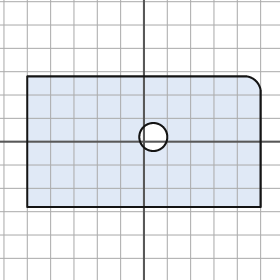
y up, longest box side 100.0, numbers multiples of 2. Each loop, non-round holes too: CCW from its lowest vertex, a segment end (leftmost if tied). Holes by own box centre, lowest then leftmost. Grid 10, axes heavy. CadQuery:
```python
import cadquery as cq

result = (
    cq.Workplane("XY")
    .moveTo(-50.0, -28.0)
    .lineTo(50.0, -28.0)
    .lineTo(50.0, 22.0)
    .threePointArc((48.0, 26.0), (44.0, 28.0))
    .lineTo(-50.0, 28.0)
    .close()
    .moveTo(4.0, 2.0)
    .circle(6.0)
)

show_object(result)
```